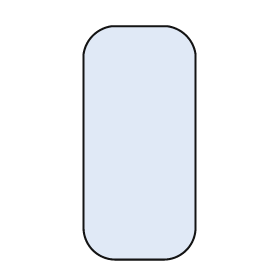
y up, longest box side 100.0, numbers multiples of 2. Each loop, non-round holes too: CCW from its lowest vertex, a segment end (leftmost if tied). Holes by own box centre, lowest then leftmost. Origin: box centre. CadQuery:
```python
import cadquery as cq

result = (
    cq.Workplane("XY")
    .moveTo(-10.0, -50.0)
    .lineTo(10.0, -50.0)
    .threePointArc((20.0, -46.0), (24.0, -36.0))
    .lineTo(24.0, 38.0)
    .threePointArc((20.0, 46.0), (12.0, 50.0))
    .lineTo(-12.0, 50.0)
    .threePointArc((-20.0, 46.0), (-24.0, 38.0))
    .lineTo(-24.0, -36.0)
    .threePointArc((-20.0, -46.0), (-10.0, -50.0))
    .close()
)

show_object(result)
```